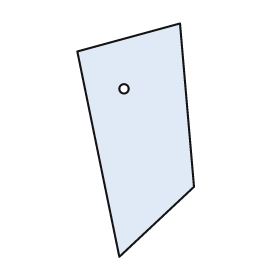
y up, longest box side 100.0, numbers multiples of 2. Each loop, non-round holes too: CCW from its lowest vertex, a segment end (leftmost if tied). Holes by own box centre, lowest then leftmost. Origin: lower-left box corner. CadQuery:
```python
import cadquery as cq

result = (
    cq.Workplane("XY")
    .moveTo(18.0, 0.0)
    .lineTo(50.0, 30.0)
    .lineTo(44.0, 100.0)
    .lineTo(0.0, 88.0)
    .close()
    .moveTo(20.0, 72.0)
    .circle(2.0)
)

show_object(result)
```